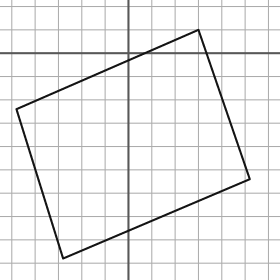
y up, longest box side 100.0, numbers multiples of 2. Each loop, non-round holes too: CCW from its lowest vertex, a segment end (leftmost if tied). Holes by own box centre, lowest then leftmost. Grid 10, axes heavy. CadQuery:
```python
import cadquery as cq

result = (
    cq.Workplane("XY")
    .moveTo(-28.0, -88.0)
    .lineTo(52.0, -54.0)
    .lineTo(30.0, 10.0)
    .lineTo(-48.0, -24.0)
    .close()
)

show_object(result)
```